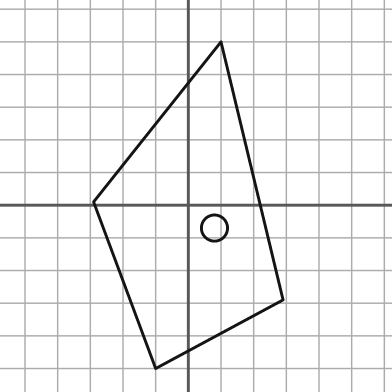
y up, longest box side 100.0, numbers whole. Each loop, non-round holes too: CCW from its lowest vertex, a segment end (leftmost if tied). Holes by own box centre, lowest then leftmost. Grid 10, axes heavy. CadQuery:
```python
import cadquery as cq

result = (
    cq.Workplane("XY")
    .moveTo(-10.0, -50.0)
    .lineTo(29.0, -29.0)
    .lineTo(10.0, 50.0)
    .lineTo(-29.0, 1.0)
    .close()
    .moveTo(8.0, -7.0)
    .circle(4.0)
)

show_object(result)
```